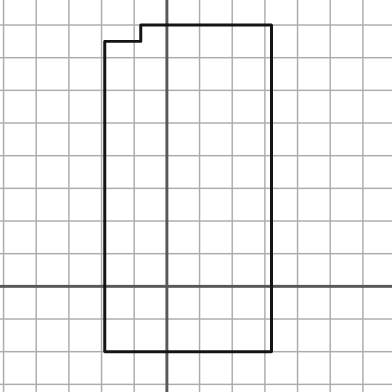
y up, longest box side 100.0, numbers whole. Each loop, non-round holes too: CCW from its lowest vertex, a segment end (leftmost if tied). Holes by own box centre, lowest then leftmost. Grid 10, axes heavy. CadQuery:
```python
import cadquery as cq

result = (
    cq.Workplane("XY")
    .moveTo(-19.0, -20.0)
    .lineTo(32.0, -20.0)
    .lineTo(32.0, 80.0)
    .lineTo(-8.0, 80.0)
    .lineTo(-8.0, 75.0)
    .lineTo(-19.0, 75.0)
    .close()
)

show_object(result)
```